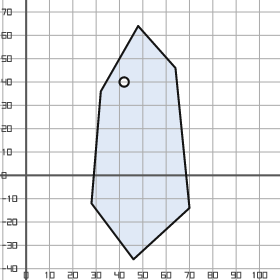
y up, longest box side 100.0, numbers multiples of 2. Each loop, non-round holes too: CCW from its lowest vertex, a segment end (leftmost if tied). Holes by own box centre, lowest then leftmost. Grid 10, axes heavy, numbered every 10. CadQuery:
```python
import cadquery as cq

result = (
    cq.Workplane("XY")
    .moveTo(46.0, -36.0)
    .lineTo(70.0, -14.0)
    .lineTo(64.0, 46.0)
    .lineTo(48.0, 64.0)
    .lineTo(32.0, 36.0)
    .lineTo(28.0, -12.0)
    .close()
    .moveTo(42.0, 40.0)
    .circle(2.0)
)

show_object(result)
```